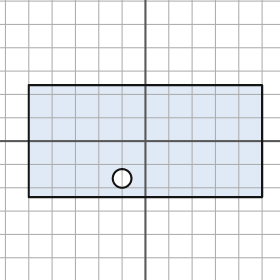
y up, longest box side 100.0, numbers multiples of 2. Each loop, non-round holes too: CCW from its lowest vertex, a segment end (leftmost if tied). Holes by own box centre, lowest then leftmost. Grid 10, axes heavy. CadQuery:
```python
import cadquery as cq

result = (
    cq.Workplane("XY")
    .moveTo(-50.0, -24.0)
    .lineTo(50.0, -24.0)
    .lineTo(50.0, 24.0)
    .lineTo(-50.0, 24.0)
    .close()
    .moveTo(-10.0, -16.0)
    .circle(4.0)
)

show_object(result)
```